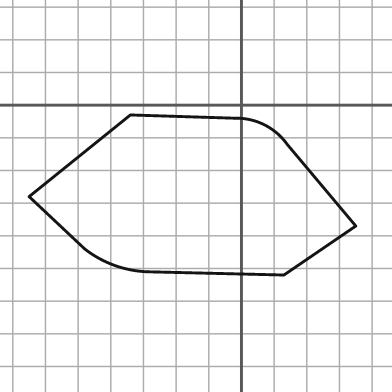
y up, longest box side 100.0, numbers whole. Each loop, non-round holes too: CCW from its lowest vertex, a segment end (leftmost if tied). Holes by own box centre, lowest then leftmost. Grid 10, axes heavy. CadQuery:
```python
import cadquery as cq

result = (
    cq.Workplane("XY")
    .moveTo(13.0, -52.0)
    .lineTo(35.0, -37.0)
    .lineTo(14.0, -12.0)
    .threePointArc((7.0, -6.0), (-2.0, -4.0))
    .lineTo(-34.0, -3.0)
    .lineTo(-65.0, -28.0)
    .lineTo(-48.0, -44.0)
    .threePointArc((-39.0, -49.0), (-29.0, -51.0))
    .close()
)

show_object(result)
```